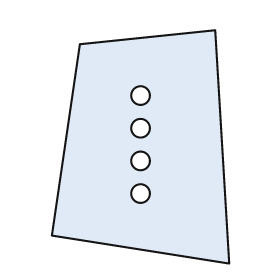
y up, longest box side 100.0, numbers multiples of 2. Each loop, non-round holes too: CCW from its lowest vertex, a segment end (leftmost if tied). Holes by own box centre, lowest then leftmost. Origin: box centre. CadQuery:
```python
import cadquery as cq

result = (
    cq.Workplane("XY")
    .moveTo(38.0, -50.0)
    .lineTo(32.0, 50.0)
    .lineTo(-26.0, 44.0)
    .lineTo(-38.0, -38.0)
    .close()
    .moveTo(0.0, -20.0)
    .circle(4.0)
    .moveTo(0.0, -6.0)
    .circle(4.0)
    .moveTo(0.0, 8.0)
    .circle(4.0)
    .moveTo(0.0, 22.0)
    .circle(4.0)
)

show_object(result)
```